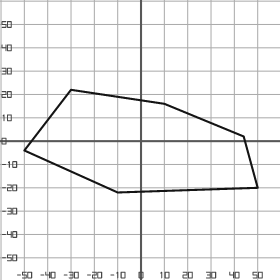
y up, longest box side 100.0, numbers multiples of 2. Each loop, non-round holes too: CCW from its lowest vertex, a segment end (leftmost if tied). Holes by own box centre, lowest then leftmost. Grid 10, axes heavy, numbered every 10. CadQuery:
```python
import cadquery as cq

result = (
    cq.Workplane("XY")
    .moveTo(-10.0, -22.0)
    .lineTo(50.0, -20.0)
    .lineTo(44.0, 2.0)
    .lineTo(10.0, 16.0)
    .lineTo(-30.0, 22.0)
    .lineTo(-50.0, -4.0)
    .close()
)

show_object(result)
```